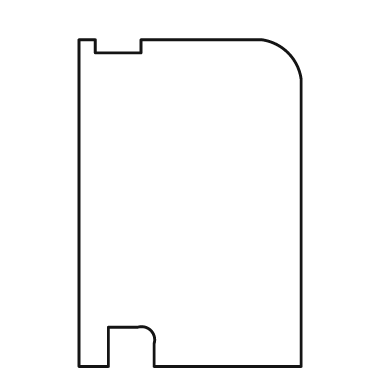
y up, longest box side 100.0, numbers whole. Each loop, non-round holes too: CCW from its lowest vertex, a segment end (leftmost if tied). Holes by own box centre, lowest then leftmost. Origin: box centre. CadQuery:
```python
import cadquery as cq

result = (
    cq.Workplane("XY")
    .moveTo(-34.0, -50.0)
    .lineTo(-25.0, -50.0)
    .lineTo(-25.0, -38.0)
    .lineTo(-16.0, -38.0)
    .threePointArc((-12.0, -39.0), (-11.0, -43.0))
    .lineTo(-11.0, -50.0)
    .lineTo(34.0, -50.0)
    .lineTo(34.0, 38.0)
    .threePointArc((30.0, 46.0), (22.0, 50.0))
    .lineTo(-15.0, 50.0)
    .lineTo(-15.0, 46.0)
    .lineTo(-29.0, 46.0)
    .lineTo(-29.0, 50.0)
    .lineTo(-34.0, 50.0)
    .close()
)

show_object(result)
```